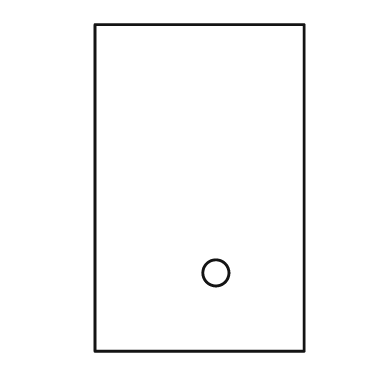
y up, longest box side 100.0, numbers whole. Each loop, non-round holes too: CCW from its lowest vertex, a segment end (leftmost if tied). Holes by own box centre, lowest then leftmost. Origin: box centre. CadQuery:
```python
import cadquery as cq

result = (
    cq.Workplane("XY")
    .moveTo(-32.0, -50.0)
    .lineTo(32.0, -50.0)
    .lineTo(32.0, 50.0)
    .lineTo(-32.0, 50.0)
    .close()
    .moveTo(5.0, -26.0)
    .circle(4.0)
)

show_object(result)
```